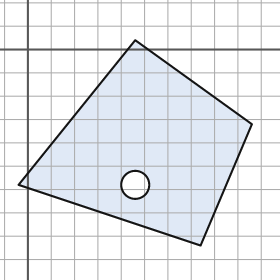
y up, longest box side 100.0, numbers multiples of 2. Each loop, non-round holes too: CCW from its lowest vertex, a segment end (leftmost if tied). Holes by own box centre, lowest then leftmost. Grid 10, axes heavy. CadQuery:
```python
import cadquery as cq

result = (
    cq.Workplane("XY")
    .moveTo(74.0, -84.0)
    .lineTo(96.0, -32.0)
    .lineTo(46.0, 4.0)
    .lineTo(-4.0, -58.0)
    .close()
    .moveTo(46.0, -58.0)
    .circle(6.0)
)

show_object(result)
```